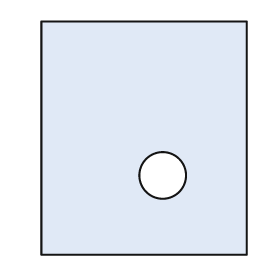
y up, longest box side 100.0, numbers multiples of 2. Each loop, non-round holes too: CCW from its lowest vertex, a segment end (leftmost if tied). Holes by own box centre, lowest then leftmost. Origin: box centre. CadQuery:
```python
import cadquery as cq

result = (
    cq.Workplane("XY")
    .moveTo(-44.0, -50.0)
    .lineTo(44.0, -50.0)
    .lineTo(44.0, 50.0)
    .lineTo(-44.0, 50.0)
    .close()
    .moveTo(8.0, -16.0)
    .circle(10.0)
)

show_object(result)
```